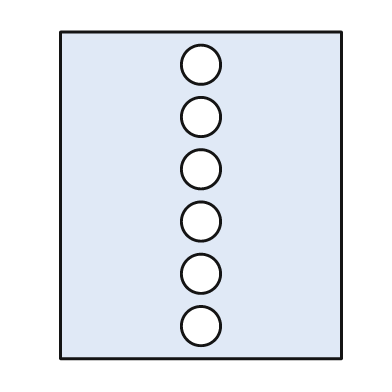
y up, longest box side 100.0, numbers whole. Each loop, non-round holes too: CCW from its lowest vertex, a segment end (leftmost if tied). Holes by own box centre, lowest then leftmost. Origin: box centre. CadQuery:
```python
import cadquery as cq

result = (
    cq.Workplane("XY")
    .moveTo(-43.0, -50.0)
    .lineTo(43.0, -50.0)
    .lineTo(43.0, 50.0)
    .lineTo(-43.0, 50.0)
    .close()
    .moveTo(0.0, -40.0)
    .circle(6.0)
    .moveTo(0.0, -24.0)
    .circle(6.0)
    .moveTo(0.0, -8.0)
    .circle(6.0)
    .moveTo(0.0, 8.0)
    .circle(6.0)
    .moveTo(0.0, 24.0)
    .circle(6.0)
    .moveTo(0.0, 40.0)
    .circle(6.0)
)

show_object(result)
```